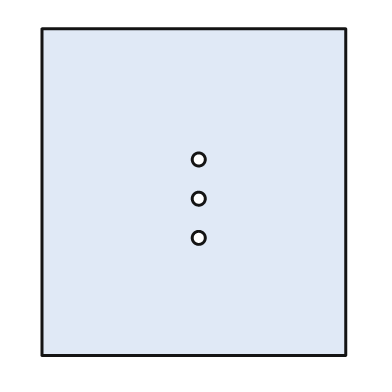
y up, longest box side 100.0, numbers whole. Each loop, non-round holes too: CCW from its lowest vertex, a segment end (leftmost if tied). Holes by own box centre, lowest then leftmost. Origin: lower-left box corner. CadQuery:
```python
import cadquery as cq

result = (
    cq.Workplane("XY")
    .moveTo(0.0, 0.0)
    .lineTo(93.0, 0.0)
    .lineTo(93.0, 100.0)
    .lineTo(0.0, 100.0)
    .close()
    .moveTo(48.0, 36.0)
    .circle(2.0)
    .moveTo(48.0, 48.0)
    .circle(2.0)
    .moveTo(48.0, 60.0)
    .circle(2.0)
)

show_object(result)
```